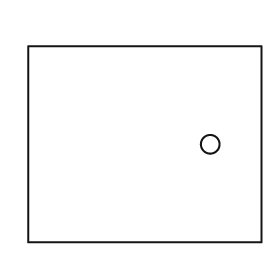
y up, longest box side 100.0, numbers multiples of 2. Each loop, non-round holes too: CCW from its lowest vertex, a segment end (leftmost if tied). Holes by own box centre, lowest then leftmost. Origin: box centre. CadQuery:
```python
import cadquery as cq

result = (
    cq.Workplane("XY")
    .moveTo(-50.0, -42.0)
    .lineTo(50.0, -42.0)
    .lineTo(50.0, 42.0)
    .lineTo(-50.0, 42.0)
    .close()
    .moveTo(28.0, 0.0)
    .circle(4.0)
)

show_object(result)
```